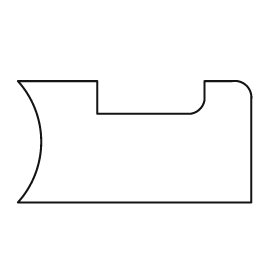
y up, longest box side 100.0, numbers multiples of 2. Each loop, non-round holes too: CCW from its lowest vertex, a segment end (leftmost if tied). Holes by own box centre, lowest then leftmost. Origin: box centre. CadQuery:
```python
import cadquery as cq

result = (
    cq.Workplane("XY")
    .moveTo(-50.0, -26.0)
    .lineTo(50.0, -26.0)
    .lineTo(50.0, 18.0)
    .threePointArc((48.0, 24.0), (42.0, 26.0))
    .lineTo(30.0, 26.0)
    .lineTo(30.0, 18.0)
    .threePointArc((28.0, 14.0), (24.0, 12.0))
    .lineTo(-16.0, 12.0)
    .lineTo(-16.0, 26.0)
    .lineTo(-50.0, 26.0)
    .threePointArc((-40.0, 0.0), (-50.0, -26.0))
    .close()
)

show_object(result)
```